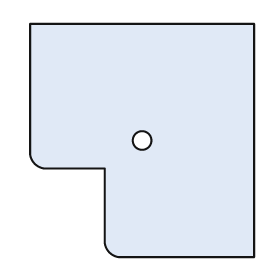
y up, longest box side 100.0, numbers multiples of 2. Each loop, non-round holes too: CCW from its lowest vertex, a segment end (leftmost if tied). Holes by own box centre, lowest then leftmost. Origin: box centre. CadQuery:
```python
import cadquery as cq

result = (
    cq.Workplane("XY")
    .moveTo(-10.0, -50.0)
    .lineTo(48.0, -50.0)
    .lineTo(48.0, 50.0)
    .lineTo(-48.0, 50.0)
    .lineTo(-48.0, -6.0)
    .threePointArc((-46.0, -10.0), (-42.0, -12.0))
    .lineTo(-16.0, -12.0)
    .lineTo(-16.0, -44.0)
    .threePointArc((-14.0, -48.0), (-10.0, -50.0))
    .close()
    .moveTo(0.0, 0.0)
    .circle(4.0)
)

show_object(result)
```